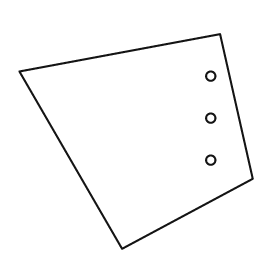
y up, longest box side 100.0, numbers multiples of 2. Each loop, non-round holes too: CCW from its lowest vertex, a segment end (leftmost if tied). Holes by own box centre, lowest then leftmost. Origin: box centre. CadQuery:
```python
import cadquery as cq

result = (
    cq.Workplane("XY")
    .moveTo(-6.0, -46.0)
    .lineTo(50.0, -16.0)
    .lineTo(36.0, 46.0)
    .lineTo(-50.0, 30.0)
    .close()
    .moveTo(32.0, -8.0)
    .circle(2.0)
    .moveTo(32.0, 10.0)
    .circle(2.0)
    .moveTo(32.0, 28.0)
    .circle(2.0)
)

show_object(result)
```